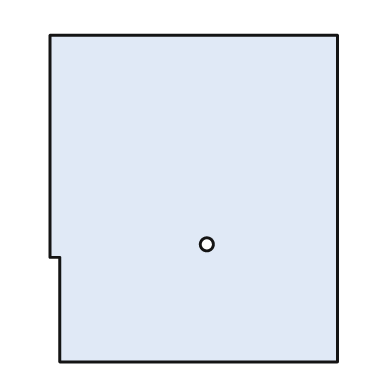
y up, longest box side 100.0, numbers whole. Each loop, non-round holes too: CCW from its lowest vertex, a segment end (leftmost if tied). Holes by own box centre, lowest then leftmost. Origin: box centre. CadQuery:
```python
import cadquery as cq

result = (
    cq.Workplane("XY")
    .moveTo(-41.0, -50.0)
    .lineTo(44.0, -50.0)
    .lineTo(44.0, 50.0)
    .lineTo(-44.0, 50.0)
    .lineTo(-44.0, -18.0)
    .lineTo(-41.0, -18.0)
    .close()
    .moveTo(4.0, -14.0)
    .circle(2.0)
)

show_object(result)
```